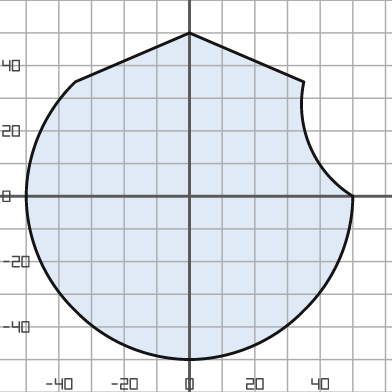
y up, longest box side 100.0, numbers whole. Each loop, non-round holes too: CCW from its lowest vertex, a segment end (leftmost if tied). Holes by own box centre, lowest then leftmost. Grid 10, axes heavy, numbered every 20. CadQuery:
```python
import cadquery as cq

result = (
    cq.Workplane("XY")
    .moveTo(0.0, -50.0)
    .threePointArc((19.0, -46.0), (35.0, -35.0))
    .threePointArc((46.0, -19.0), (50.0, 0.0))
    .threePointArc((37.0, 15.0), (35.0, 35.0))
    .lineTo(0.0, 50.0)
    .lineTo(-35.0, 35.0)
    .threePointArc((-46.0, 19.0), (-50.0, 0.0))
    .threePointArc((-46.0, -19.0), (-35.0, -35.0))
    .threePointArc((-19.0, -46.0), (0.0, -50.0))
    .close()
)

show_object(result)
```